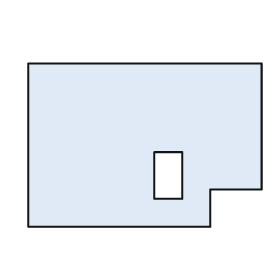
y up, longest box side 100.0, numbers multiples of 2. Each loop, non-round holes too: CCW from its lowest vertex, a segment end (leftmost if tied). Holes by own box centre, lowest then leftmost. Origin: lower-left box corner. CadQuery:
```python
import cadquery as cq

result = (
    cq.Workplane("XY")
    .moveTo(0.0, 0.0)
    .lineTo(78.0, 0.0)
    .lineTo(78.0, 16.0)
    .lineTo(100.0, 16.0)
    .lineTo(100.0, 70.0)
    .lineTo(0.0, 70.0)
    .close()
    .moveTo(54.0, 12.0)
    .lineTo(66.0, 12.0)
    .lineTo(66.0, 32.0)
    .lineTo(54.0, 32.0)
    .close()
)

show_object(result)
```